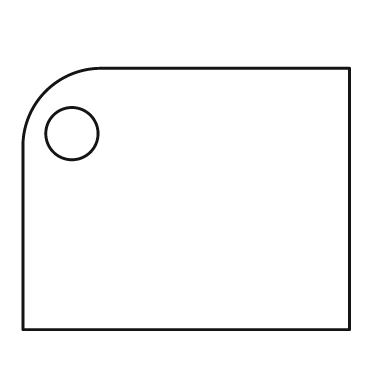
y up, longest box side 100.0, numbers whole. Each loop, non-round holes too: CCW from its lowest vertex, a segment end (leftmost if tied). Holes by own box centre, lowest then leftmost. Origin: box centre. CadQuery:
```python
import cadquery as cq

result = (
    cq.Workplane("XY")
    .moveTo(-50.0, -40.0)
    .lineTo(50.0, -40.0)
    .lineTo(50.0, 40.0)
    .lineTo(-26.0, 40.0)
    .threePointArc((-43.0, 33.0), (-50.0, 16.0))
    .close()
    .moveTo(-35.0, 20.0)
    .circle(8.0)
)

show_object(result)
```